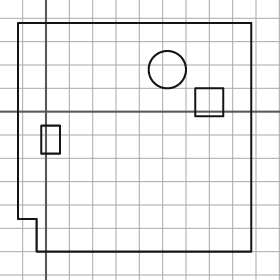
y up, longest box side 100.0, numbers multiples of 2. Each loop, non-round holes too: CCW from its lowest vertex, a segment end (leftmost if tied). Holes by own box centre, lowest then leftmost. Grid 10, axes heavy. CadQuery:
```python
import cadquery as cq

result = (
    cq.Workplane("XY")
    .moveTo(-4.0, -60.0)
    .lineTo(88.0, -60.0)
    .lineTo(88.0, 38.0)
    .lineTo(-12.0, 38.0)
    .lineTo(-12.0, -46.0)
    .lineTo(-4.0, -46.0)
    .close()
    .moveTo(-2.0, -18.0)
    .lineTo(6.0, -18.0)
    .lineTo(6.0, -6.0)
    .lineTo(-2.0, -6.0)
    .close()
    .moveTo(64.0, -2.0)
    .lineTo(76.0, -2.0)
    .lineTo(76.0, 10.0)
    .lineTo(64.0, 10.0)
    .close()
    .moveTo(52.0, 18.0)
    .circle(8.0)
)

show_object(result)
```